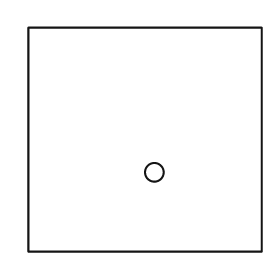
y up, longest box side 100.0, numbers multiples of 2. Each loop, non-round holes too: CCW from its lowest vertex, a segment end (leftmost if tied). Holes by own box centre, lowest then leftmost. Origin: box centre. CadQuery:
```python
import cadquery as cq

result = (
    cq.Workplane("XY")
    .moveTo(-50.0, -48.0)
    .lineTo(50.0, -48.0)
    .lineTo(50.0, 48.0)
    .lineTo(-50.0, 48.0)
    .close()
    .moveTo(4.0, -14.0)
    .circle(4.0)
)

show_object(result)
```